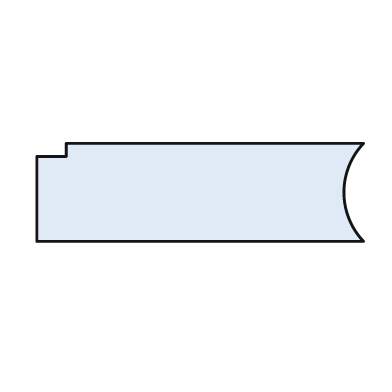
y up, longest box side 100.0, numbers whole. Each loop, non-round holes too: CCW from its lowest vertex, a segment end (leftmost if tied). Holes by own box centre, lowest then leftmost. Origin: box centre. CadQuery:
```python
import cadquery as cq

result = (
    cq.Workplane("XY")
    .moveTo(-50.0, -15.0)
    .lineTo(50.0, -15.0)
    .threePointArc((44.0, 0.0), (50.0, 15.0))
    .lineTo(-41.0, 15.0)
    .lineTo(-41.0, 11.0)
    .lineTo(-50.0, 11.0)
    .close()
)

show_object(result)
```